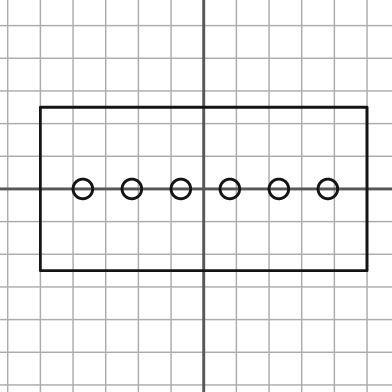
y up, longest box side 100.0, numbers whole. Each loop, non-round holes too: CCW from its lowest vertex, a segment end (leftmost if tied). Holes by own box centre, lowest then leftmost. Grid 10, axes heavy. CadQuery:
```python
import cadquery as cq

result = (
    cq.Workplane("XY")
    .moveTo(-50.0, -25.0)
    .lineTo(50.0, -25.0)
    .lineTo(50.0, 25.0)
    .lineTo(-50.0, 25.0)
    .close()
    .moveTo(-37.0, 0.0)
    .circle(3.0)
    .moveTo(-22.0, 0.0)
    .circle(3.0)
    .moveTo(-7.0, 0.0)
    .circle(3.0)
    .moveTo(8.0, 0.0)
    .circle(3.0)
    .moveTo(23.0, 0.0)
    .circle(3.0)
    .moveTo(38.0, 0.0)
    .circle(3.0)
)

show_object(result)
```